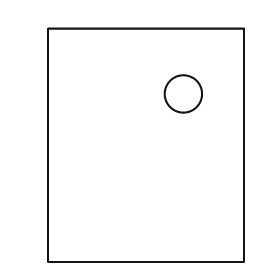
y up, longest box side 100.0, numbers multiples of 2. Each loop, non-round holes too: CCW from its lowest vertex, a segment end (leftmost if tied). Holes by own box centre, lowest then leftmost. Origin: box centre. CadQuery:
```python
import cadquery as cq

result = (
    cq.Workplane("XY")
    .moveTo(-42.0, -50.0)
    .lineTo(42.0, -50.0)
    .lineTo(42.0, 50.0)
    .lineTo(-42.0, 50.0)
    .close()
    .moveTo(16.0, 22.0)
    .circle(8.0)
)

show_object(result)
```